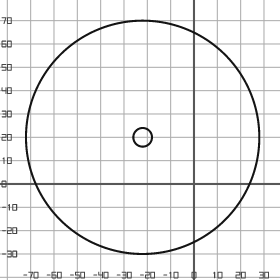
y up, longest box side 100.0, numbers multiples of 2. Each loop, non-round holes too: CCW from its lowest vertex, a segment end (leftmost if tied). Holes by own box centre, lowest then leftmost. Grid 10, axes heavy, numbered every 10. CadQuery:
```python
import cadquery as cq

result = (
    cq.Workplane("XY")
    .moveTo(-22.0, 20.0)
    .circle(50.0)
    .moveTo(-22.0, 20.0)
    .circle(4.0)
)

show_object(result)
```